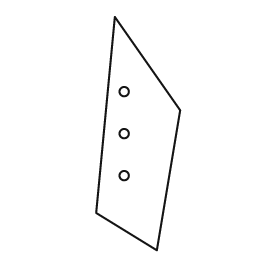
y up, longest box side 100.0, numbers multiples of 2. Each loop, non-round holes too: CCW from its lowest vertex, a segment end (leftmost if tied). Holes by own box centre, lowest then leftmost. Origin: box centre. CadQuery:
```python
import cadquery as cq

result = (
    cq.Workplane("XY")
    .moveTo(8.0, -50.0)
    .lineTo(18.0, 10.0)
    .lineTo(-10.0, 50.0)
    .lineTo(-18.0, -34.0)
    .close()
    .moveTo(-6.0, -18.0)
    .circle(2.0)
    .moveTo(-6.0, 0.0)
    .circle(2.0)
    .moveTo(-6.0, 18.0)
    .circle(2.0)
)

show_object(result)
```